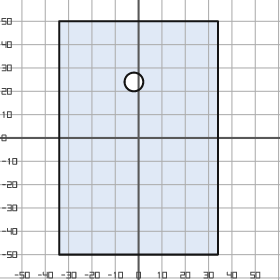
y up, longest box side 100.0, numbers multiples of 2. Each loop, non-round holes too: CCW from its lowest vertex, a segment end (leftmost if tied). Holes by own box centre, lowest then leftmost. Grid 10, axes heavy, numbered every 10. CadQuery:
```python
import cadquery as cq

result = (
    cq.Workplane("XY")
    .moveTo(-34.0, -50.0)
    .lineTo(34.0, -50.0)
    .lineTo(34.0, 50.0)
    .lineTo(-34.0, 50.0)
    .close()
    .moveTo(-2.0, 24.0)
    .circle(4.0)
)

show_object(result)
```